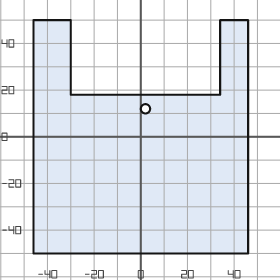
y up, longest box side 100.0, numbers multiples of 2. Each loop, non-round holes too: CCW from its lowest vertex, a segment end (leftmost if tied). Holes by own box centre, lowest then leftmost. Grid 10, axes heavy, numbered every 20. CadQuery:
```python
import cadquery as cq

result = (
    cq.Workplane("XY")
    .moveTo(-46.0, -50.0)
    .lineTo(46.0, -50.0)
    .lineTo(46.0, 50.0)
    .lineTo(34.0, 50.0)
    .lineTo(34.0, 18.0)
    .lineTo(-30.0, 18.0)
    .lineTo(-30.0, 50.0)
    .lineTo(-46.0, 50.0)
    .close()
    .moveTo(2.0, 12.0)
    .circle(2.0)
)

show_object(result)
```